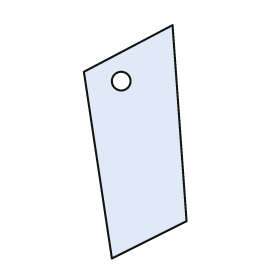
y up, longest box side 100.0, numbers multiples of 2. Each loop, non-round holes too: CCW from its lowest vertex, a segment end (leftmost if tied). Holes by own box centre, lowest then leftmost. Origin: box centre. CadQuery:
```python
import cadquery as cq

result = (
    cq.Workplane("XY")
    .moveTo(-10.0, -50.0)
    .lineTo(22.0, -34.0)
    .lineTo(16.0, 50.0)
    .lineTo(-22.0, 30.0)
    .close()
    .moveTo(-6.0, 26.0)
    .circle(4.0)
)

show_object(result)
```